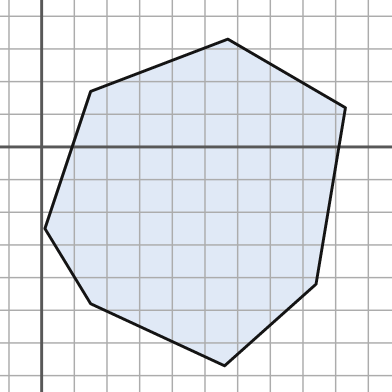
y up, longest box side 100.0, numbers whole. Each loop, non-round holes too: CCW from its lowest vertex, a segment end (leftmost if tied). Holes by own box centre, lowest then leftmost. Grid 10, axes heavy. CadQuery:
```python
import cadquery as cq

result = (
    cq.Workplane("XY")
    .moveTo(56.0, -67.0)
    .lineTo(84.0, -42.0)
    .lineTo(93.0, 12.0)
    .lineTo(57.0, 33.0)
    .lineTo(15.0, 17.0)
    .lineTo(1.0, -25.0)
    .lineTo(15.0, -48.0)
    .close()
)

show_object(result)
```